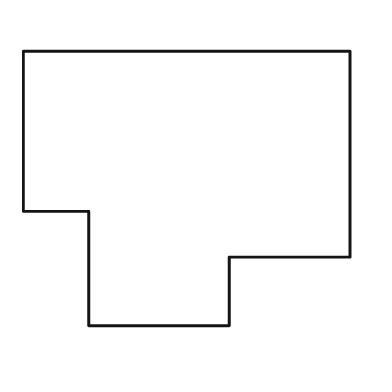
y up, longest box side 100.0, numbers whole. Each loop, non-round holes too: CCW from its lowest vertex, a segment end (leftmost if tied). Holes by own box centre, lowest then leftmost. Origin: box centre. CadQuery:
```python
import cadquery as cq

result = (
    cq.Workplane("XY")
    .moveTo(-30.0, -42.0)
    .lineTo(13.0, -42.0)
    .lineTo(13.0, -21.0)
    .lineTo(50.0, -21.0)
    .lineTo(50.0, 42.0)
    .lineTo(-50.0, 42.0)
    .lineTo(-50.0, -7.0)
    .lineTo(-30.0, -7.0)
    .close()
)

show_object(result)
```